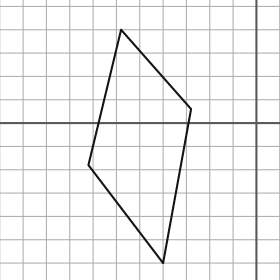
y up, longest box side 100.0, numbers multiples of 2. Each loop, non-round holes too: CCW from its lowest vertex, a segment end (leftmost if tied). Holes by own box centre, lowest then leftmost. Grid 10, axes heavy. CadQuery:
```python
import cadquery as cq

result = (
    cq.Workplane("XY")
    .moveTo(-40.0, -60.0)
    .lineTo(-28.0, 6.0)
    .lineTo(-58.0, 40.0)
    .lineTo(-72.0, -18.0)
    .close()
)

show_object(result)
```